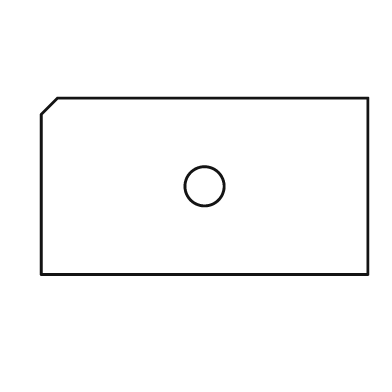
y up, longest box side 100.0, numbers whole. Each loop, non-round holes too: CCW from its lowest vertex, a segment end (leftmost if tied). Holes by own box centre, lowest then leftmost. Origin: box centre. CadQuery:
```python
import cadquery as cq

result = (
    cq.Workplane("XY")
    .moveTo(-50.0, -27.0)
    .lineTo(50.0, -27.0)
    .lineTo(50.0, 27.0)
    .lineTo(-45.0, 27.0)
    .lineTo(-50.0, 22.0)
    .close()
    .moveTo(0.0, 0.0)
    .circle(6.0)
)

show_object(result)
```